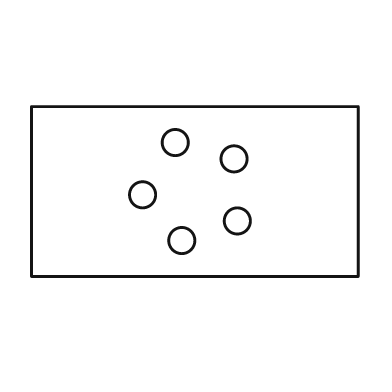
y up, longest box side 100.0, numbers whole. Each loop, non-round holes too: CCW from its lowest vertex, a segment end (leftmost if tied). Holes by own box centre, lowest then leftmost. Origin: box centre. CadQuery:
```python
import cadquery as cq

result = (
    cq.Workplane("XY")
    .moveTo(-50.0, -26.0)
    .lineTo(50.0, -26.0)
    .lineTo(50.0, 26.0)
    .lineTo(-50.0, 26.0)
    .close()
    .moveTo(-4.0, -15.0)
    .circle(4.0)
    .moveTo(13.0, -9.0)
    .circle(4.0)
    .moveTo(-16.0, -1.0)
    .circle(4.0)
    .moveTo(12.0, 10.0)
    .circle(4.0)
    .moveTo(-6.0, 15.0)
    .circle(4.0)
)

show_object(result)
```